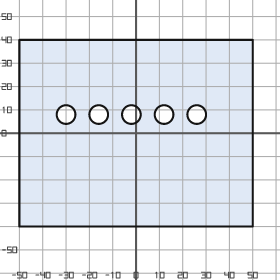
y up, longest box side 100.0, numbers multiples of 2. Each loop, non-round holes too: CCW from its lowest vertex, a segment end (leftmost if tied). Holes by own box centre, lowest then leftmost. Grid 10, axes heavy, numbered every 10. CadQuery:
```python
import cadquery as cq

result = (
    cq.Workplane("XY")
    .moveTo(-50.0, -40.0)
    .lineTo(50.0, -40.0)
    .lineTo(50.0, 40.0)
    .lineTo(-50.0, 40.0)
    .close()
    .moveTo(-30.0, 8.0)
    .circle(4.0)
    .moveTo(-16.0, 8.0)
    .circle(4.0)
    .moveTo(-2.0, 8.0)
    .circle(4.0)
    .moveTo(12.0, 8.0)
    .circle(4.0)
    .moveTo(26.0, 8.0)
    .circle(4.0)
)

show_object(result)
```